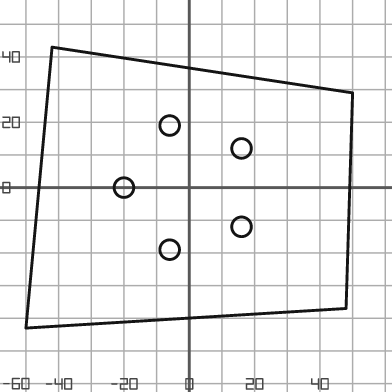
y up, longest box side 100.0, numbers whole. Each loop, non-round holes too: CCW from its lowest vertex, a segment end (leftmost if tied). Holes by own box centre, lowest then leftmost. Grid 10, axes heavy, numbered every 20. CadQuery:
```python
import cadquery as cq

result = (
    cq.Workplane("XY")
    .moveTo(-50.0, -43.0)
    .lineTo(48.0, -37.0)
    .lineTo(50.0, 29.0)
    .lineTo(-42.0, 43.0)
    .close()
    .moveTo(-6.0, -19.0)
    .circle(3.0)
    .moveTo(16.0, -12.0)
    .circle(3.0)
    .moveTo(-20.0, 0.0)
    .circle(3.0)
    .moveTo(16.0, 12.0)
    .circle(3.0)
    .moveTo(-6.0, 19.0)
    .circle(3.0)
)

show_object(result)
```